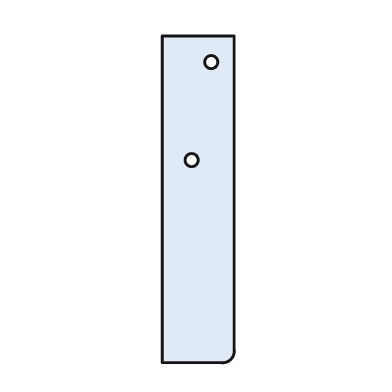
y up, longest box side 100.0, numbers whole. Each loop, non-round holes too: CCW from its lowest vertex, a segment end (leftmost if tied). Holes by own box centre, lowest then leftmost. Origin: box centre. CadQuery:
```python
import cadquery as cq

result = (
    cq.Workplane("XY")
    .moveTo(-11.0, -50.0)
    .lineTo(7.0, -50.0)
    .threePointArc((10.0, -49.0), (11.0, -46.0))
    .lineTo(11.0, 50.0)
    .lineTo(-11.0, 50.0)
    .close()
    .moveTo(-2.0, 12.0)
    .circle(2.0)
    .moveTo(4.0, 42.0)
    .circle(2.0)
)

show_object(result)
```